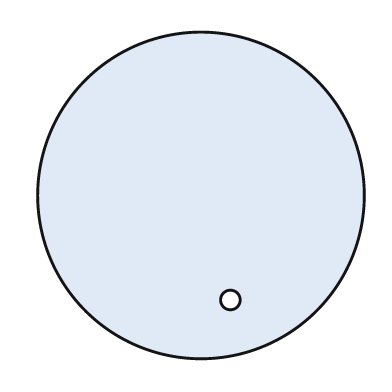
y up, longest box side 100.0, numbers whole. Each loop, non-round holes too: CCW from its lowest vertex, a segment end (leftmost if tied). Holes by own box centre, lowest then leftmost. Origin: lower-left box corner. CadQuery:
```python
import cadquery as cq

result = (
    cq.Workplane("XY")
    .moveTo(50.0, 50.0)
    .circle(50.0)
    .moveTo(59.0, 18.0)
    .circle(3.0)
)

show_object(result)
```